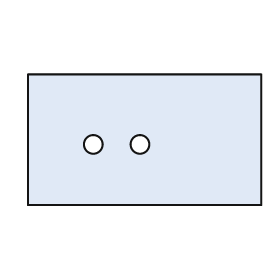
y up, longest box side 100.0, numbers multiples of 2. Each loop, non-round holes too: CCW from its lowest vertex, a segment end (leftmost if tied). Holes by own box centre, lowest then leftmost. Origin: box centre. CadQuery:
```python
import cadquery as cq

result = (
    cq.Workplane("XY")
    .moveTo(-50.0, -28.0)
    .lineTo(50.0, -28.0)
    .lineTo(50.0, 28.0)
    .lineTo(-50.0, 28.0)
    .close()
    .moveTo(-22.0, -2.0)
    .circle(4.0)
    .moveTo(-2.0, -2.0)
    .circle(4.0)
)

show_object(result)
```